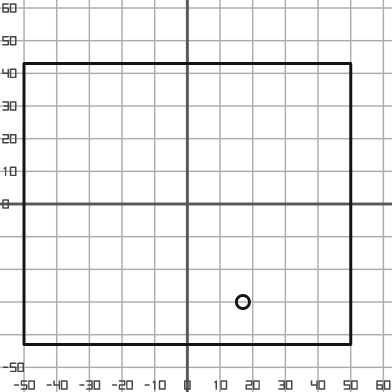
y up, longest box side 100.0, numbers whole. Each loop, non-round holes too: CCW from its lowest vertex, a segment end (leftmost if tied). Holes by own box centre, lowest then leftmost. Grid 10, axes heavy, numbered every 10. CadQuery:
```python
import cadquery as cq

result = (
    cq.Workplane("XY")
    .moveTo(-50.0, -43.0)
    .lineTo(50.0, -43.0)
    .lineTo(50.0, 43.0)
    .lineTo(-50.0, 43.0)
    .close()
    .moveTo(17.0, -30.0)
    .circle(2.0)
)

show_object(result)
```